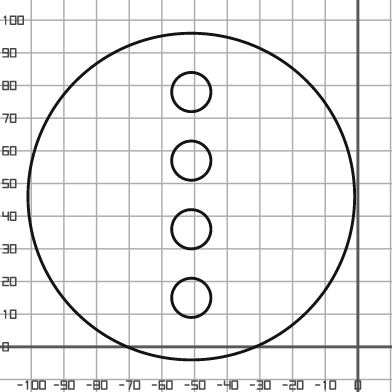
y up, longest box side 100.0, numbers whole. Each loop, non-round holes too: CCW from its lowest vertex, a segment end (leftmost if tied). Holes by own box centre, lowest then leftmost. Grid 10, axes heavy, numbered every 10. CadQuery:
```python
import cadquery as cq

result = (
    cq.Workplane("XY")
    .moveTo(-51.0, 46.0)
    .circle(50.0)
    .moveTo(-51.0, 15.0)
    .circle(6.0)
    .moveTo(-51.0, 36.0)
    .circle(6.0)
    .moveTo(-51.0, 57.0)
    .circle(6.0)
    .moveTo(-51.0, 78.0)
    .circle(6.0)
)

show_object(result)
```